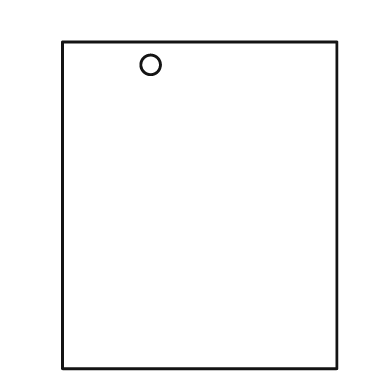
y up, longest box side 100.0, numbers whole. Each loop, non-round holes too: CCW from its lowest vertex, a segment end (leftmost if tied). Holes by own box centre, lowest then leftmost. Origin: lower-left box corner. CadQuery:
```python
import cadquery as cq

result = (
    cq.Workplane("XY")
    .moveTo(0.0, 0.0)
    .lineTo(84.0, 0.0)
    .lineTo(84.0, 100.0)
    .lineTo(0.0, 100.0)
    .close()
    .moveTo(27.0, 93.0)
    .circle(3.0)
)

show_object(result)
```